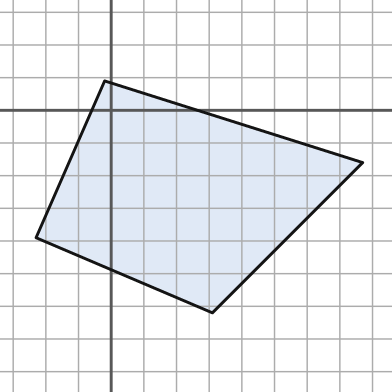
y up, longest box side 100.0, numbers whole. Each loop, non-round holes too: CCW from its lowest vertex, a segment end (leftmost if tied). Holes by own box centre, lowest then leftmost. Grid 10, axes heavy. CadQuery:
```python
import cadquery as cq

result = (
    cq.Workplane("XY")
    .moveTo(31.0, -62.0)
    .lineTo(77.0, -16.0)
    .lineTo(-2.0, 9.0)
    .lineTo(-23.0, -39.0)
    .close()
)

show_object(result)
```